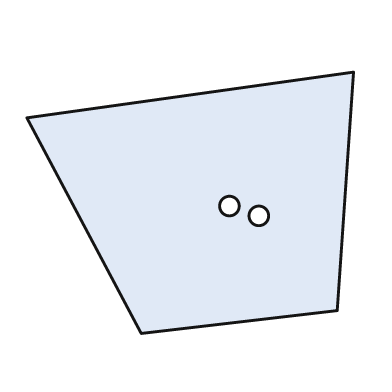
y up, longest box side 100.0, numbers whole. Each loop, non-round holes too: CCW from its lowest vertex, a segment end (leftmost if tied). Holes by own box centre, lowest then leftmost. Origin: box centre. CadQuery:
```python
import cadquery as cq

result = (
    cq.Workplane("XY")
    .moveTo(-15.0, -40.0)
    .lineTo(45.0, -33.0)
    .lineTo(50.0, 40.0)
    .lineTo(-50.0, 26.0)
    .close()
    .moveTo(21.0, -4.0)
    .circle(3.0)
    .moveTo(12.0, -1.0)
    .circle(3.0)
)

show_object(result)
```